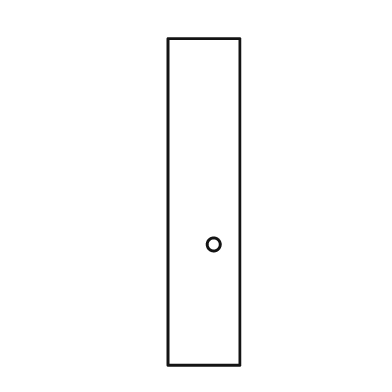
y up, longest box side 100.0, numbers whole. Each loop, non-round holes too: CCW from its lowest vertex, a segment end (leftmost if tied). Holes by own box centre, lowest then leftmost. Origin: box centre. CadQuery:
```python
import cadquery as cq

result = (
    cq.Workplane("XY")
    .moveTo(-11.0, -50.0)
    .lineTo(11.0, -50.0)
    .lineTo(11.0, 50.0)
    .lineTo(-11.0, 50.0)
    .close()
    .moveTo(3.0, -13.0)
    .circle(2.0)
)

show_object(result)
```